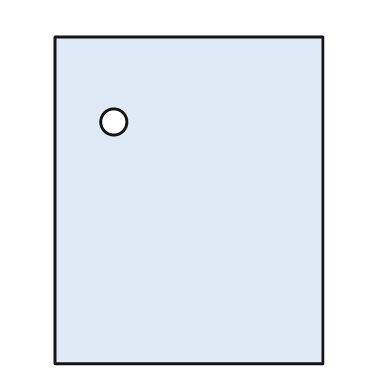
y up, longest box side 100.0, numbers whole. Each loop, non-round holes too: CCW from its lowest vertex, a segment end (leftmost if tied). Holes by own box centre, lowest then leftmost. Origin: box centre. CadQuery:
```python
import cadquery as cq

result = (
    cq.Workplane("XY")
    .moveTo(-41.0, -50.0)
    .lineTo(41.0, -50.0)
    .lineTo(41.0, 50.0)
    .lineTo(-41.0, 50.0)
    .close()
    .moveTo(-23.0, 24.0)
    .circle(4.0)
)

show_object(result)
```